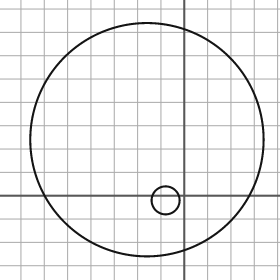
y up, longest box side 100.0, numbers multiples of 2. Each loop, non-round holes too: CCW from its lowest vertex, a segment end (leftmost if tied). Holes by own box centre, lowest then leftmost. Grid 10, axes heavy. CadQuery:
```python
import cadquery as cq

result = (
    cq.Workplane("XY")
    .moveTo(-16.0, 24.0)
    .circle(50.0)
    .moveTo(-8.0, -2.0)
    .circle(6.0)
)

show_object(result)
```